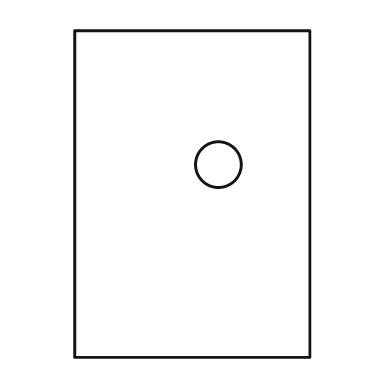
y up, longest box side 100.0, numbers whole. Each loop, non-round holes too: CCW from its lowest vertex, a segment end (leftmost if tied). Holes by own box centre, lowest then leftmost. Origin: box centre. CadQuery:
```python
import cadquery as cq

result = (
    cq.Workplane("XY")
    .moveTo(-36.0, -50.0)
    .lineTo(36.0, -50.0)
    .lineTo(36.0, 50.0)
    .lineTo(-36.0, 50.0)
    .close()
    .moveTo(8.0, 9.0)
    .circle(7.0)
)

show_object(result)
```